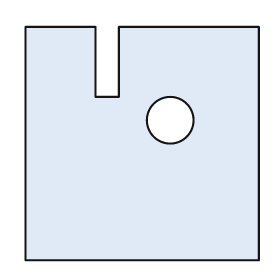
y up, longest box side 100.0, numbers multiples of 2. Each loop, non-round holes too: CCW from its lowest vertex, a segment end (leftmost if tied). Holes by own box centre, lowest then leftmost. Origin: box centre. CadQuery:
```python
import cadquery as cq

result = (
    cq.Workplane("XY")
    .moveTo(-50.0, -50.0)
    .lineTo(50.0, -50.0)
    .lineTo(50.0, 50.0)
    .lineTo(-10.0, 50.0)
    .lineTo(-10.0, 20.0)
    .lineTo(-20.0, 20.0)
    .lineTo(-20.0, 50.0)
    .lineTo(-50.0, 50.0)
    .close()
    .moveTo(12.0, 10.0)
    .circle(10.0)
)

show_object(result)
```